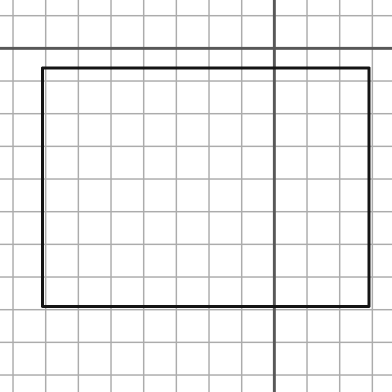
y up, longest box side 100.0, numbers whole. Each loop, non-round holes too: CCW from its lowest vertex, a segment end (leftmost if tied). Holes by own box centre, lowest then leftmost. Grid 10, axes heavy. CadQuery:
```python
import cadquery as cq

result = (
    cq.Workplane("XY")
    .moveTo(-71.0, -79.0)
    .lineTo(29.0, -79.0)
    .lineTo(29.0, -6.0)
    .lineTo(-71.0, -6.0)
    .close()
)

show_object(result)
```